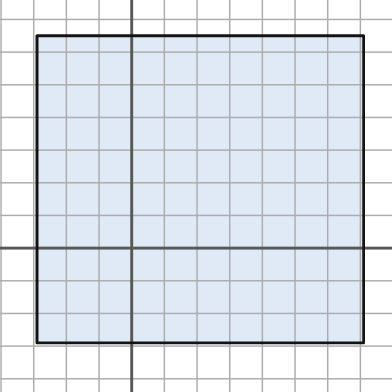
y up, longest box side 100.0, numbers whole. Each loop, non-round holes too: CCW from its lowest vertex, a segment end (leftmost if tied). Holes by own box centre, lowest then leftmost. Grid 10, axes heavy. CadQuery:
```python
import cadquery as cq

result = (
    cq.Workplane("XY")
    .moveTo(-29.0, -29.0)
    .lineTo(71.0, -29.0)
    .lineTo(71.0, 65.0)
    .lineTo(-29.0, 65.0)
    .close()
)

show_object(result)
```